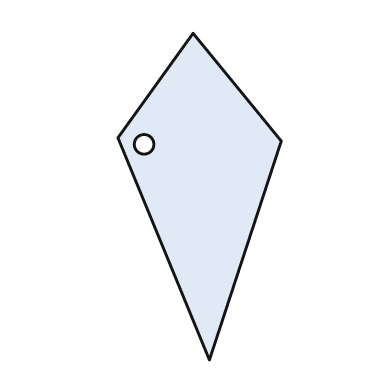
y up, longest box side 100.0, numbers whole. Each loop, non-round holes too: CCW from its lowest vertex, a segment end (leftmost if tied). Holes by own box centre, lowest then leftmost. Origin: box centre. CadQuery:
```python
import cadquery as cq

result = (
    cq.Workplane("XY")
    .moveTo(3.0, -50.0)
    .lineTo(25.0, 17.0)
    .lineTo(-2.0, 50.0)
    .lineTo(-25.0, 18.0)
    .close()
    .moveTo(-17.0, 16.0)
    .circle(3.0)
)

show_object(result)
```